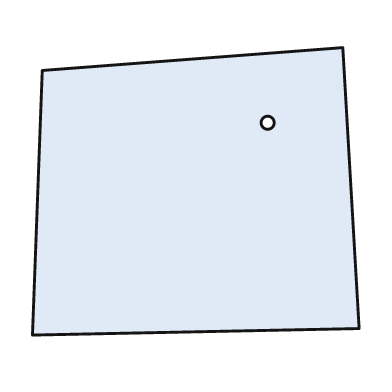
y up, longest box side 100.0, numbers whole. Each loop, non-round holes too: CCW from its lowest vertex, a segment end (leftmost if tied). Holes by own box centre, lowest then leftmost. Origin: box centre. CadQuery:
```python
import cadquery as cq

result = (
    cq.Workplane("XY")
    .moveTo(-50.0, -44.0)
    .lineTo(50.0, -42.0)
    .lineTo(45.0, 44.0)
    .lineTo(-47.0, 37.0)
    .close()
    .moveTo(22.0, 21.0)
    .circle(2.0)
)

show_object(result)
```